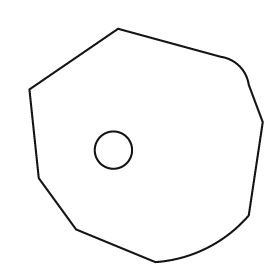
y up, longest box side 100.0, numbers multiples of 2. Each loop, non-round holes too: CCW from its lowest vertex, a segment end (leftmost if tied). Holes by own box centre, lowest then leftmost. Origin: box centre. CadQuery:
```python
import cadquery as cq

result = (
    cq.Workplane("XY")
    .moveTo(4.0, -50.0)
    .threePointArc((26.0, -44.0), (44.0, -30.0))
    .lineTo(50.0, 10.0)
    .lineTo(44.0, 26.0)
    .threePointArc((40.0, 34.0), (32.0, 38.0))
    .lineTo(-12.0, 50.0)
    .lineTo(-50.0, 24.0)
    .lineTo(-46.0, -14.0)
    .lineTo(-30.0, -36.0)
    .close()
    .moveTo(-14.0, -2.0)
    .circle(8.0)
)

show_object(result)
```